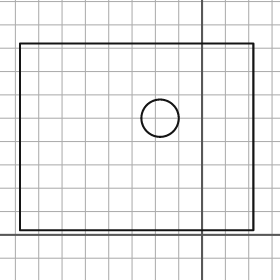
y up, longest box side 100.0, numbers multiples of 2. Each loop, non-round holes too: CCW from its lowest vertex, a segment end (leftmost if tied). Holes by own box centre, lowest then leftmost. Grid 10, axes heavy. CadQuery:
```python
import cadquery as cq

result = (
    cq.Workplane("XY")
    .moveTo(-78.0, 2.0)
    .lineTo(22.0, 2.0)
    .lineTo(22.0, 82.0)
    .lineTo(-78.0, 82.0)
    .close()
    .moveTo(-18.0, 50.0)
    .circle(8.0)
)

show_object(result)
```